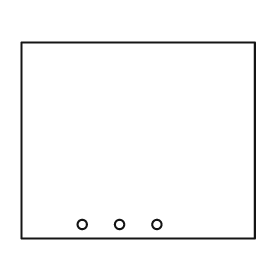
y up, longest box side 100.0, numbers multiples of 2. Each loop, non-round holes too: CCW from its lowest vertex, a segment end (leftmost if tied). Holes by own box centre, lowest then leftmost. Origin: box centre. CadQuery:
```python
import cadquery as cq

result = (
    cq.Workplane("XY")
    .moveTo(-50.0, -42.0)
    .lineTo(50.0, -42.0)
    .lineTo(50.0, 42.0)
    .lineTo(-50.0, 42.0)
    .close()
    .moveTo(-24.0, -36.0)
    .circle(2.0)
    .moveTo(-8.0, -36.0)
    .circle(2.0)
    .moveTo(8.0, -36.0)
    .circle(2.0)
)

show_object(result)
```